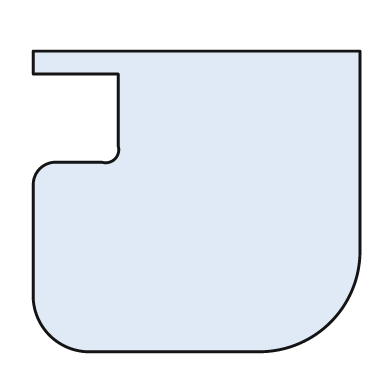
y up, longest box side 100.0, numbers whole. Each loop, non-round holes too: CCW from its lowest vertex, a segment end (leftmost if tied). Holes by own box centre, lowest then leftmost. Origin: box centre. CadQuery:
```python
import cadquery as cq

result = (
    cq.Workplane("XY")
    .moveTo(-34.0, -46.0)
    .lineTo(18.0, -46.0)
    .threePointArc((41.0, -37.0), (50.0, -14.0))
    .lineTo(50.0, 46.0)
    .lineTo(-50.0, 46.0)
    .lineTo(-50.0, 39.0)
    .lineTo(-24.0, 39.0)
    .lineTo(-24.0, 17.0)
    .threePointArc((-25.0, 13.0), (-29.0, 12.0))
    .lineTo(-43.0, 12.0)
    .threePointArc((-48.0, 10.0), (-50.0, 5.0))
    .lineTo(-50.0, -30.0)
    .threePointArc((-45.0, -41.0), (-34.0, -46.0))
    .close()
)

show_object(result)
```